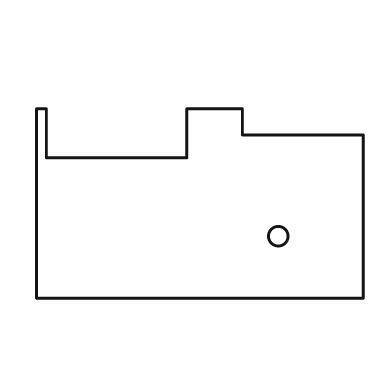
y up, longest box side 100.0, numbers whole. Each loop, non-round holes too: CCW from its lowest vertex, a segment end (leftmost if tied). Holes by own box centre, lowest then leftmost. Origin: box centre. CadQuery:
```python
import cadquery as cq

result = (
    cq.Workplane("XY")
    .moveTo(-50.0, -29.0)
    .lineTo(50.0, -29.0)
    .lineTo(50.0, 21.0)
    .lineTo(13.0, 21.0)
    .lineTo(13.0, 29.0)
    .lineTo(-4.0, 29.0)
    .lineTo(-4.0, 14.0)
    .lineTo(-47.0, 14.0)
    .lineTo(-47.0, 29.0)
    .lineTo(-50.0, 29.0)
    .close()
    .moveTo(24.0, -10.0)
    .circle(3.0)
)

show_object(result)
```